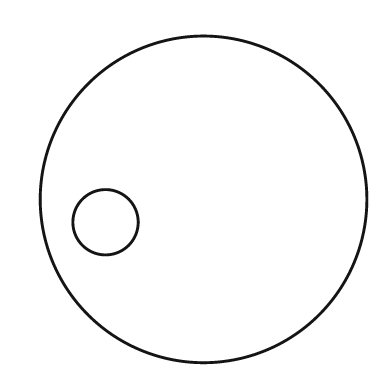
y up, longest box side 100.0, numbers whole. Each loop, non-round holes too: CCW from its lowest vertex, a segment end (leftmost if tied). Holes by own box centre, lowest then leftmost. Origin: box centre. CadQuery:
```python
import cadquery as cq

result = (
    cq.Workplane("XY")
    .moveTo(0.0, 0.0)
    .circle(50.0)
    .moveTo(-30.0, -7.0)
    .circle(10.0)
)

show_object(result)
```